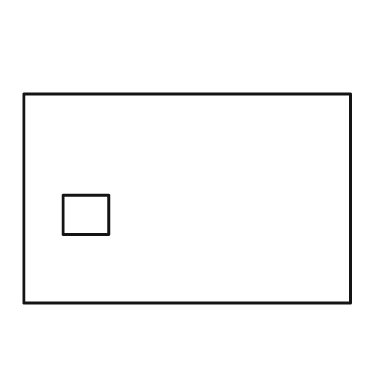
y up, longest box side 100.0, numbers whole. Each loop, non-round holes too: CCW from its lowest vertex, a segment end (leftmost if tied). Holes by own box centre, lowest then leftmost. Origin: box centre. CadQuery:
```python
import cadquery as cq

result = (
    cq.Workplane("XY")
    .moveTo(-50.0, -32.0)
    .lineTo(50.0, -32.0)
    .lineTo(50.0, 32.0)
    .lineTo(-50.0, 32.0)
    .close()
    .moveTo(-38.0, -11.0)
    .lineTo(-24.0, -11.0)
    .lineTo(-24.0, 1.0)
    .lineTo(-38.0, 1.0)
    .close()
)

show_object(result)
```